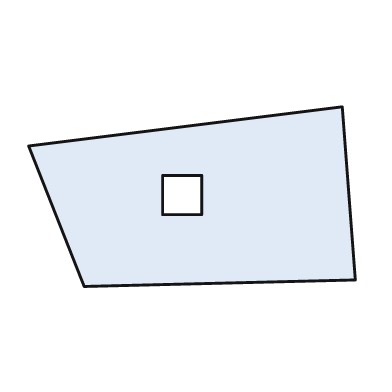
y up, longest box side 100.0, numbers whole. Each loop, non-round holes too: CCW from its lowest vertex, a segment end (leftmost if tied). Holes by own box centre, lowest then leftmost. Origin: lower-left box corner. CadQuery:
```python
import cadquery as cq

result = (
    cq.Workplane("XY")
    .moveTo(17.0, 0.0)
    .lineTo(100.0, 2.0)
    .lineTo(96.0, 55.0)
    .lineTo(0.0, 43.0)
    .close()
    .moveTo(41.0, 22.0)
    .lineTo(53.0, 22.0)
    .lineTo(53.0, 34.0)
    .lineTo(41.0, 34.0)
    .close()
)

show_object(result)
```